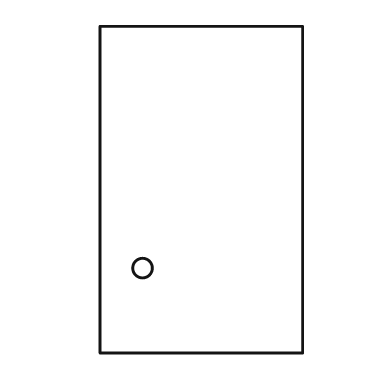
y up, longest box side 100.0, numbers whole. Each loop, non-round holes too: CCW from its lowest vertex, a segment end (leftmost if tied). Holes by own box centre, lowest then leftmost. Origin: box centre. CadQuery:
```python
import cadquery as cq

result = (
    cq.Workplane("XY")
    .moveTo(-31.0, -50.0)
    .lineTo(31.0, -50.0)
    .lineTo(31.0, 50.0)
    .lineTo(-31.0, 50.0)
    .close()
    .moveTo(-18.0, -24.0)
    .circle(3.0)
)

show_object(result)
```